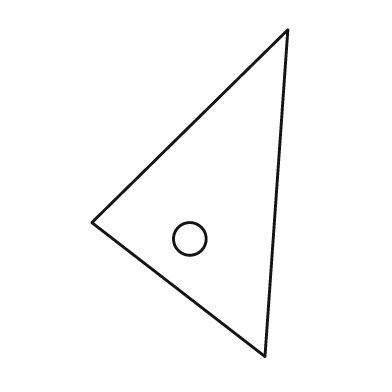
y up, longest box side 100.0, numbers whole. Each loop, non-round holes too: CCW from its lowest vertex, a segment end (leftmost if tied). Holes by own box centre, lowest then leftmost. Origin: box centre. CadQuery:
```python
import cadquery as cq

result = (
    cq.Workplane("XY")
    .moveTo(23.0, -50.0)
    .lineTo(30.0, 50.0)
    .lineTo(-30.0, -9.0)
    .close()
    .moveTo(0.0, -14.0)
    .circle(5.0)
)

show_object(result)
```